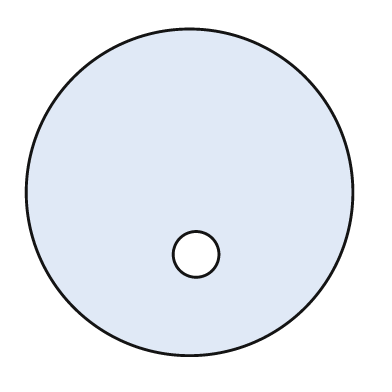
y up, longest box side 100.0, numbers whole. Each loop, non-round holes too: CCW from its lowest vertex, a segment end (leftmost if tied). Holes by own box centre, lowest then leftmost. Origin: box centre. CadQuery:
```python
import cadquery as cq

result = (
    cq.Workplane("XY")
    .moveTo(0.0, 0.0)
    .circle(50.0)
    .moveTo(2.0, -19.0)
    .circle(7.0)
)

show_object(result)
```